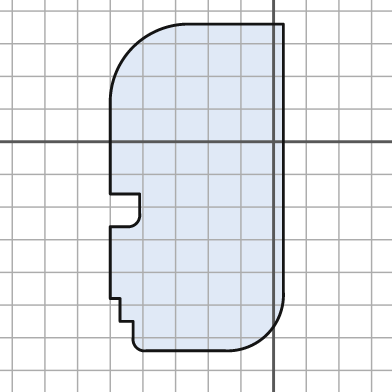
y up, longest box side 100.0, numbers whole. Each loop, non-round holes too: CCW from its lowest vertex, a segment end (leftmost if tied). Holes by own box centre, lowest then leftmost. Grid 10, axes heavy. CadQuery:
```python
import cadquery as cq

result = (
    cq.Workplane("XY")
    .moveTo(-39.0, -64.0)
    .lineTo(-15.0, -64.0)
    .threePointArc((-2.0, -59.0), (3.0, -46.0))
    .lineTo(3.0, 36.0)
    .lineTo(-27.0, 36.0)
    .threePointArc((-43.0, 29.0), (-50.0, 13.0))
    .lineTo(-50.0, -16.0)
    .lineTo(-41.0, -16.0)
    .lineTo(-41.0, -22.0)
    .threePointArc((-42.0, -25.0), (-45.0, -26.0))
    .lineTo(-50.0, -26.0)
    .lineTo(-50.0, -48.0)
    .lineTo(-47.0, -48.0)
    .lineTo(-47.0, -55.0)
    .lineTo(-43.0, -55.0)
    .lineTo(-43.0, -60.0)
    .threePointArc((-42.0, -63.0), (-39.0, -64.0))
    .close()
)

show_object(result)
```